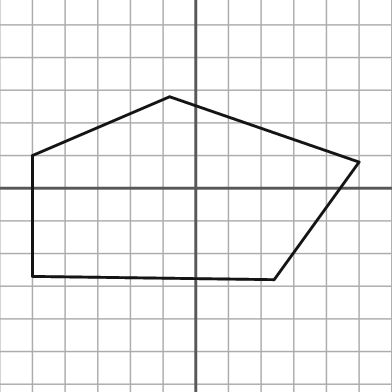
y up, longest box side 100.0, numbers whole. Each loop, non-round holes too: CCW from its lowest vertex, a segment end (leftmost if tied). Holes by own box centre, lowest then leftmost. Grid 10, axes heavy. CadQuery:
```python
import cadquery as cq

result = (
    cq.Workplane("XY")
    .moveTo(24.0, -28.0)
    .lineTo(50.0, 8.0)
    .lineTo(-8.0, 28.0)
    .lineTo(-50.0, 10.0)
    .lineTo(-50.0, -27.0)
    .close()
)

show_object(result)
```